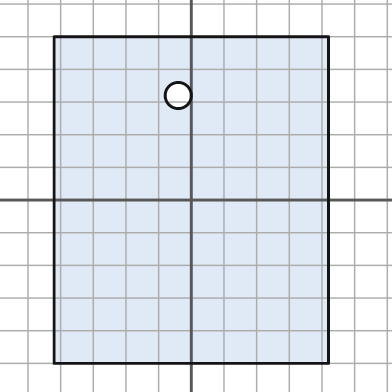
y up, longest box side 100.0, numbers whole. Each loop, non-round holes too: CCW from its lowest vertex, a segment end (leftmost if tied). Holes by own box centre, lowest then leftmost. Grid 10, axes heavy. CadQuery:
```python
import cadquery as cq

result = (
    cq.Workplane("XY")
    .moveTo(-42.0, -50.0)
    .lineTo(42.0, -50.0)
    .lineTo(42.0, 50.0)
    .lineTo(-42.0, 50.0)
    .close()
    .moveTo(-4.0, 32.0)
    .circle(4.0)
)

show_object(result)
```